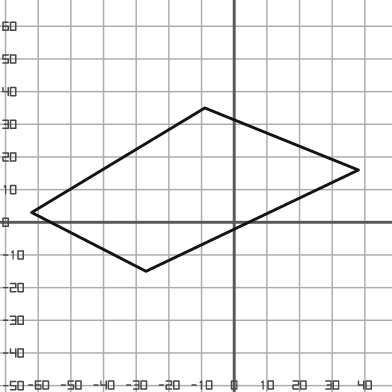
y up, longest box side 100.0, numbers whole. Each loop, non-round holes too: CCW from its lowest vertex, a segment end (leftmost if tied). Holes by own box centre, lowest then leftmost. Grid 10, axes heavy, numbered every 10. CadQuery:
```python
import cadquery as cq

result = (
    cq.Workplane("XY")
    .moveTo(-27.0, -15.0)
    .lineTo(38.0, 16.0)
    .lineTo(-9.0, 35.0)
    .lineTo(-62.0, 3.0)
    .close()
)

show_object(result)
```